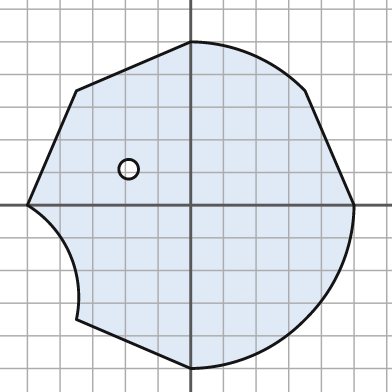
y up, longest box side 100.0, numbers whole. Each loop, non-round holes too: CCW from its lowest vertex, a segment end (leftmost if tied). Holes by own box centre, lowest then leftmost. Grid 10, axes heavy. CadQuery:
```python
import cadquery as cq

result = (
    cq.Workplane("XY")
    .moveTo(0.0, -50.0)
    .threePointArc((19.0, -46.0), (35.0, -35.0))
    .threePointArc((46.0, -19.0), (50.0, 0.0))
    .lineTo(35.0, 35.0)
    .threePointArc((19.0, 46.0), (0.0, 50.0))
    .lineTo(-35.0, 35.0)
    .lineTo(-50.0, 0.0)
    .threePointArc((-37.0, -15.0), (-35.0, -35.0))
    .close()
    .moveTo(-19.0, 11.0)
    .circle(3.0)
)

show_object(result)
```